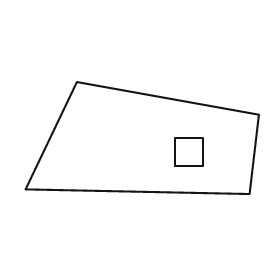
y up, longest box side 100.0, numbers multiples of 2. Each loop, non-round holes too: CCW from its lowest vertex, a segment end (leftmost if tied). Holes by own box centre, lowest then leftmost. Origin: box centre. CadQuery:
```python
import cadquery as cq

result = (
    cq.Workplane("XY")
    .moveTo(46.0, -24.0)
    .lineTo(50.0, 10.0)
    .lineTo(-28.0, 24.0)
    .lineTo(-50.0, -22.0)
    .close()
    .moveTo(14.0, -12.0)
    .lineTo(26.0, -12.0)
    .lineTo(26.0, 0.0)
    .lineTo(14.0, 0.0)
    .close()
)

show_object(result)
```